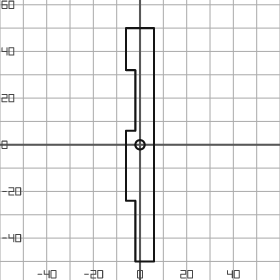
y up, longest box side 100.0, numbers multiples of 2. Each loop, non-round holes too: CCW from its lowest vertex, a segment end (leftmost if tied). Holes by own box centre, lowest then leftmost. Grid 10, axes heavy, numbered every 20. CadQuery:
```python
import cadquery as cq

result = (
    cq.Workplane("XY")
    .moveTo(-2.0, -50.0)
    .lineTo(6.0, -50.0)
    .lineTo(6.0, 50.0)
    .lineTo(-6.0, 50.0)
    .lineTo(-6.0, 32.0)
    .lineTo(-2.0, 32.0)
    .lineTo(-2.0, 6.0)
    .lineTo(-6.0, 6.0)
    .lineTo(-6.0, -24.0)
    .lineTo(-2.0, -24.0)
    .close()
    .moveTo(0.0, 0.0)
    .circle(2.0)
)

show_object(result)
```